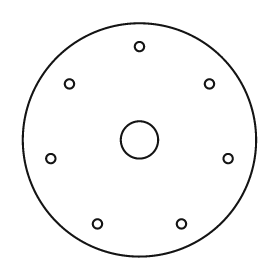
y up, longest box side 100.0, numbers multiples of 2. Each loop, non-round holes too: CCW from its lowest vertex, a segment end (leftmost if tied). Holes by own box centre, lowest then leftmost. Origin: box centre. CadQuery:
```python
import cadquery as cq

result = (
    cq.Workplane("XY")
    .moveTo(0.0, 0.0)
    .circle(50.0)
    .moveTo(-18.0, -36.0)
    .circle(2.0)
    .moveTo(18.0, -36.0)
    .circle(2.0)
    .moveTo(-38.0, -8.0)
    .circle(2.0)
    .moveTo(38.0, -8.0)
    .circle(2.0)
    .moveTo(0.0, 0.0)
    .circle(8.0)
    .moveTo(-30.0, 24.0)
    .circle(2.0)
    .moveTo(30.0, 24.0)
    .circle(2.0)
    .moveTo(0.0, 40.0)
    .circle(2.0)
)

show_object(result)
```